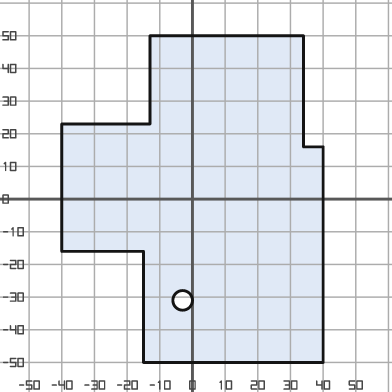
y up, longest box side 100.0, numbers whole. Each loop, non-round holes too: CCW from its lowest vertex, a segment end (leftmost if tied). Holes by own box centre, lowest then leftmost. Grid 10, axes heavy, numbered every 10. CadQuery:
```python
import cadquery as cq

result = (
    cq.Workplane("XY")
    .moveTo(-15.0, -50.0)
    .lineTo(40.0, -50.0)
    .lineTo(40.0, 16.0)
    .lineTo(34.0, 16.0)
    .lineTo(34.0, 50.0)
    .lineTo(-13.0, 50.0)
    .lineTo(-13.0, 23.0)
    .lineTo(-40.0, 23.0)
    .lineTo(-40.0, -16.0)
    .lineTo(-15.0, -16.0)
    .close()
    .moveTo(-3.0, -31.0)
    .circle(3.0)
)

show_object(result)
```